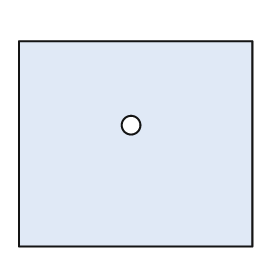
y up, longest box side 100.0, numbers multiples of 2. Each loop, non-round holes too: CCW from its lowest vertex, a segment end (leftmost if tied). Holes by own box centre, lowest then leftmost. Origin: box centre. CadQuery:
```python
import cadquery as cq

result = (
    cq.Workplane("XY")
    .moveTo(-50.0, -44.0)
    .lineTo(50.0, -44.0)
    .lineTo(50.0, 44.0)
    .lineTo(-50.0, 44.0)
    .close()
    .moveTo(-2.0, 8.0)
    .circle(4.0)
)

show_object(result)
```